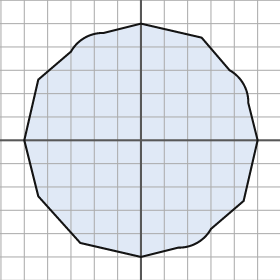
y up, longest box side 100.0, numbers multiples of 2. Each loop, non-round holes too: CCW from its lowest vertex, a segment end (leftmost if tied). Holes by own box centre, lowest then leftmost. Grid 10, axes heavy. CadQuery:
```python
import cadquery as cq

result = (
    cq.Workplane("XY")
    .moveTo(0.0, -50.0)
    .lineTo(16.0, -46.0)
    .threePointArc((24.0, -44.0), (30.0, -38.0))
    .lineTo(44.0, -26.0)
    .lineTo(50.0, 0.0)
    .lineTo(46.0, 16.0)
    .threePointArc((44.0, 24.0), (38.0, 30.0))
    .lineTo(26.0, 44.0)
    .lineTo(0.0, 50.0)
    .lineTo(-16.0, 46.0)
    .threePointArc((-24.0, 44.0), (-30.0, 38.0))
    .lineTo(-44.0, 26.0)
    .lineTo(-50.0, 0.0)
    .lineTo(-44.0, -24.0)
    .lineTo(-26.0, -44.0)
    .close()
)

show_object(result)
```